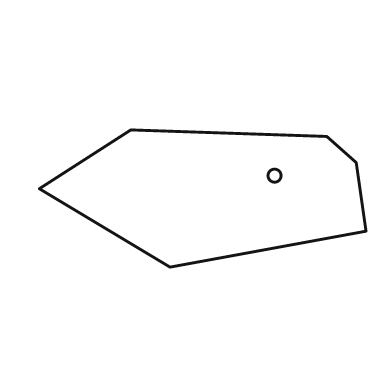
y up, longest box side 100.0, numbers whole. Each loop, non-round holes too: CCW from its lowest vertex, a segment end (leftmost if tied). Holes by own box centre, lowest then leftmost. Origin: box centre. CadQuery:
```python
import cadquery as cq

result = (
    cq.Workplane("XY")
    .moveTo(-10.0, -21.0)
    .lineTo(50.0, -10.0)
    .lineTo(47.0, 11.0)
    .lineTo(38.0, 19.0)
    .lineTo(-22.0, 21.0)
    .lineTo(-50.0, 3.0)
    .close()
    .moveTo(22.0, 7.0)
    .circle(2.0)
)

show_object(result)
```